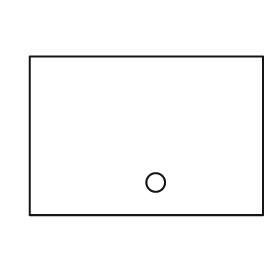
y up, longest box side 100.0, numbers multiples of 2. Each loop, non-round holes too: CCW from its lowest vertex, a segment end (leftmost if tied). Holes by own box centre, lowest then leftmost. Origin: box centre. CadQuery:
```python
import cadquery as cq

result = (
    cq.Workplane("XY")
    .moveTo(-50.0, -34.0)
    .lineTo(50.0, -34.0)
    .lineTo(50.0, 34.0)
    .lineTo(-50.0, 34.0)
    .close()
    .moveTo(4.0, -20.0)
    .circle(4.0)
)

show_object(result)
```